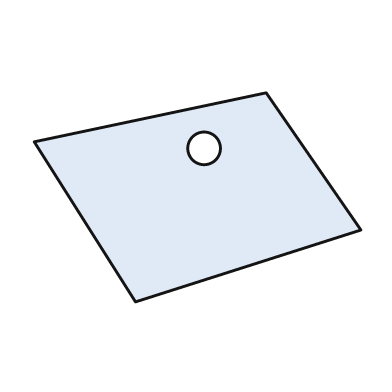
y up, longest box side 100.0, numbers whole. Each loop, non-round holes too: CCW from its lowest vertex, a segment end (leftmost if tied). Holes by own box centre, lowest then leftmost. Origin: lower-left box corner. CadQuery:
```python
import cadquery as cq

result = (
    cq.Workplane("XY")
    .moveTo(31.0, 0.0)
    .lineTo(100.0, 22.0)
    .lineTo(71.0, 64.0)
    .lineTo(0.0, 49.0)
    .close()
    .moveTo(52.0, 47.0)
    .circle(5.0)
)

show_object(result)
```